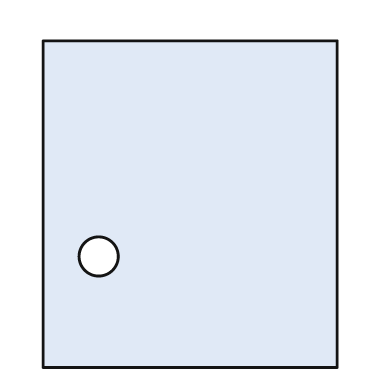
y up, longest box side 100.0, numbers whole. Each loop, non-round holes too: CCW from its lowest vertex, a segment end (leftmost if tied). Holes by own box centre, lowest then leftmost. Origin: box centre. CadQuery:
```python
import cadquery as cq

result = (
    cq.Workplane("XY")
    .moveTo(-45.0, -50.0)
    .lineTo(45.0, -50.0)
    .lineTo(45.0, 50.0)
    .lineTo(-45.0, 50.0)
    .close()
    .moveTo(-28.0, -16.0)
    .circle(6.0)
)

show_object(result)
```